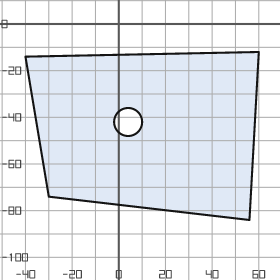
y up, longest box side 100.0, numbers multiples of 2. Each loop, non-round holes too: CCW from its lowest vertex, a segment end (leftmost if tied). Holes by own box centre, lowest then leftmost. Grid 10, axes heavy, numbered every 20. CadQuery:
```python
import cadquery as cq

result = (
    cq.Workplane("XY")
    .moveTo(56.0, -84.0)
    .lineTo(60.0, -12.0)
    .lineTo(-40.0, -14.0)
    .lineTo(-30.0, -74.0)
    .close()
    .moveTo(4.0, -42.0)
    .circle(6.0)
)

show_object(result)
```